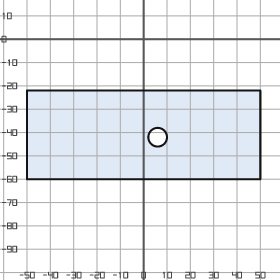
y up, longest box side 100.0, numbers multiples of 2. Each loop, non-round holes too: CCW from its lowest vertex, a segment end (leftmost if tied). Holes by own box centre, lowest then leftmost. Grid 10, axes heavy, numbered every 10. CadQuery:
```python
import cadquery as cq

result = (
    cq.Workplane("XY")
    .moveTo(-50.0, -60.0)
    .lineTo(50.0, -60.0)
    .lineTo(50.0, -22.0)
    .lineTo(-50.0, -22.0)
    .close()
    .moveTo(6.0, -42.0)
    .circle(4.0)
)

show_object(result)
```